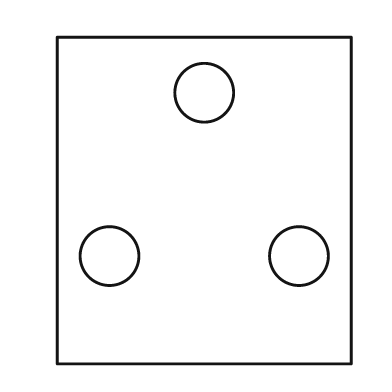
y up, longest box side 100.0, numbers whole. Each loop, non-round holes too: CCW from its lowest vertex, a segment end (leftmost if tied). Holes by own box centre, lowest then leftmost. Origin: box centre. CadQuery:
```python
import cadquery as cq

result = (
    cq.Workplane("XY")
    .moveTo(-45.0, -50.0)
    .lineTo(45.0, -50.0)
    .lineTo(45.0, 50.0)
    .lineTo(-45.0, 50.0)
    .close()
    .moveTo(-29.0, -17.0)
    .circle(9.0)
    .moveTo(29.0, -17.0)
    .circle(9.0)
    .moveTo(0.0, 33.0)
    .circle(9.0)
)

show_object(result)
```